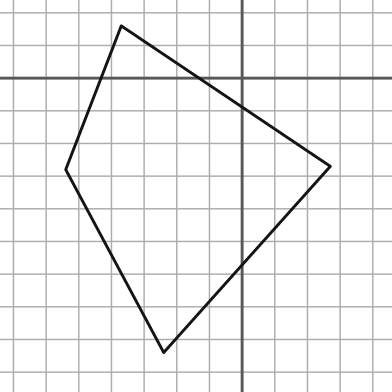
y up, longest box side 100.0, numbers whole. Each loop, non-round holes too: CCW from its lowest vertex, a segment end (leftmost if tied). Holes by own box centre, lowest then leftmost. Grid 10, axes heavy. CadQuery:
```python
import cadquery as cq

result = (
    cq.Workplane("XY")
    .moveTo(-24.0, -84.0)
    .lineTo(27.0, -27.0)
    .lineTo(-37.0, 16.0)
    .lineTo(-54.0, -28.0)
    .close()
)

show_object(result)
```